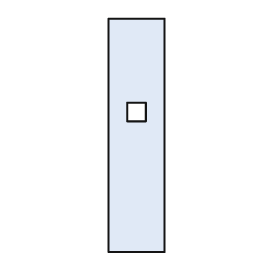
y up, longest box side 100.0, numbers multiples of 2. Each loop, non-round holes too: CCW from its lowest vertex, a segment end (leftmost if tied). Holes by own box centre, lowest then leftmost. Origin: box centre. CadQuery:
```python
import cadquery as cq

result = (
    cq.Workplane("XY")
    .moveTo(-12.0, -50.0)
    .lineTo(12.0, -50.0)
    .lineTo(12.0, 50.0)
    .lineTo(-12.0, 50.0)
    .close()
    .moveTo(-4.0, 6.0)
    .lineTo(4.0, 6.0)
    .lineTo(4.0, 14.0)
    .lineTo(-4.0, 14.0)
    .close()
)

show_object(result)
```